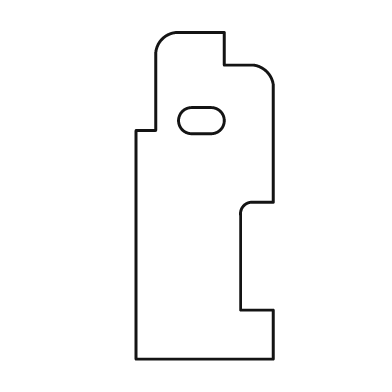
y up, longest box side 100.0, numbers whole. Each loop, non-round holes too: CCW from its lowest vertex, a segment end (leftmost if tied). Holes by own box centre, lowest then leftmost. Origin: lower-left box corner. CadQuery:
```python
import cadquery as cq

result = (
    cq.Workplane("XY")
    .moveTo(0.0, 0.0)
    .lineTo(42.0, 0.0)
    .lineTo(42.0, 15.0)
    .lineTo(32.0, 15.0)
    .lineTo(32.0, 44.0)
    .threePointArc((33.0, 47.0), (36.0, 48.0))
    .lineTo(42.0, 48.0)
    .lineTo(42.0, 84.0)
    .threePointArc((40.0, 88.0), (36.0, 90.0))
    .lineTo(27.0, 90.0)
    .lineTo(27.0, 100.0)
    .lineTo(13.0, 100.0)
    .threePointArc((8.0, 98.0), (6.0, 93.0))
    .lineTo(6.0, 70.0)
    .lineTo(0.0, 70.0)
    .close()
    .moveTo(17.0, 69.0)
    .lineTo(23.0, 69.0)
    .threePointArc((27.0, 73.0), (23.0, 77.0))
    .lineTo(17.0, 77.0)
    .threePointArc((13.0, 73.0), (17.0, 69.0))
    .close()
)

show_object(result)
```